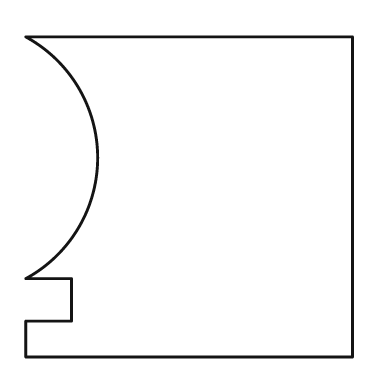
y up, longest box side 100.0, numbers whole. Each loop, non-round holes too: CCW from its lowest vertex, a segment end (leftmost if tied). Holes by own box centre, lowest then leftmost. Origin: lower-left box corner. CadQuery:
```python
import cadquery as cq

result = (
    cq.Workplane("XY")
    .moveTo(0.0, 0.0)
    .lineTo(100.0, 0.0)
    .lineTo(100.0, 98.0)
    .lineTo(0.0, 98.0)
    .threePointArc((22.0, 61.0), (0.0, 24.0))
    .lineTo(14.0, 24.0)
    .lineTo(14.0, 11.0)
    .lineTo(0.0, 11.0)
    .close()
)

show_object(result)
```